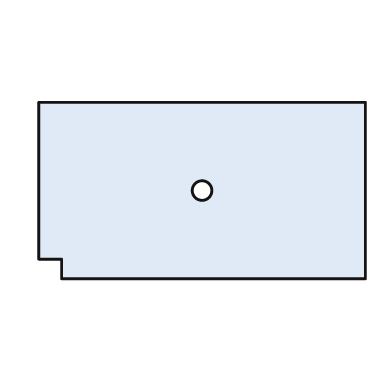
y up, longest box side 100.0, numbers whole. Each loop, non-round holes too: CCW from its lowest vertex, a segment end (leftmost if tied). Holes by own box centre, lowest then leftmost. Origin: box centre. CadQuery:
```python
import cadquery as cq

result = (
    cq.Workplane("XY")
    .moveTo(-43.0, -27.0)
    .lineTo(50.0, -27.0)
    .lineTo(50.0, 27.0)
    .lineTo(-50.0, 27.0)
    .lineTo(-50.0, -21.0)
    .lineTo(-43.0, -21.0)
    .close()
    .moveTo(0.0, 0.0)
    .circle(3.0)
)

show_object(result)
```